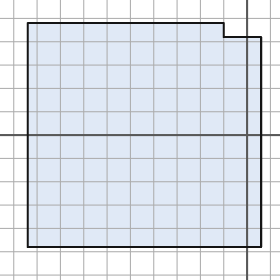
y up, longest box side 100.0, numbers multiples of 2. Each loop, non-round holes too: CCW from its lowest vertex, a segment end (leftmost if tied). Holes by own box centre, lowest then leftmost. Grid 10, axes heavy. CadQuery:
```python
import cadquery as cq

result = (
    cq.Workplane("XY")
    .moveTo(-94.0, -48.0)
    .lineTo(6.0, -48.0)
    .lineTo(6.0, 42.0)
    .lineTo(-10.0, 42.0)
    .lineTo(-10.0, 48.0)
    .lineTo(-94.0, 48.0)
    .close()
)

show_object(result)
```